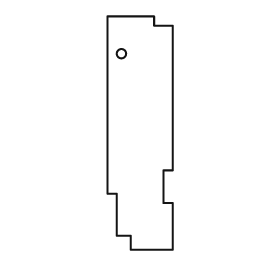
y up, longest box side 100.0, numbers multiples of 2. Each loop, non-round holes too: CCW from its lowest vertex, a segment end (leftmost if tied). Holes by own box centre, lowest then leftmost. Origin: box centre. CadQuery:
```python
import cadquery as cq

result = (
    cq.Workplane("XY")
    .moveTo(-4.0, -50.0)
    .lineTo(14.0, -50.0)
    .lineTo(14.0, -30.0)
    .lineTo(10.0, -30.0)
    .lineTo(10.0, -16.0)
    .lineTo(14.0, -16.0)
    .lineTo(14.0, 46.0)
    .lineTo(6.0, 46.0)
    .lineTo(6.0, 50.0)
    .lineTo(-14.0, 50.0)
    .lineTo(-14.0, -26.0)
    .lineTo(-10.0, -26.0)
    .lineTo(-10.0, -44.0)
    .lineTo(-4.0, -44.0)
    .close()
    .moveTo(-8.0, 34.0)
    .circle(2.0)
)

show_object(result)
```